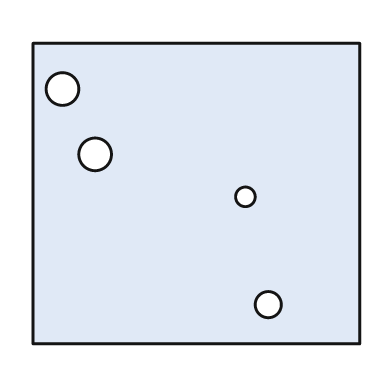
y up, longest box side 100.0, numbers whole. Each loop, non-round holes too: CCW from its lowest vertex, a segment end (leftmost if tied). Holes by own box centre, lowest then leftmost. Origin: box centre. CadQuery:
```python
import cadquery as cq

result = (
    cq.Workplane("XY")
    .moveTo(-50.0, -46.0)
    .lineTo(50.0, -46.0)
    .lineTo(50.0, 46.0)
    .lineTo(-50.0, 46.0)
    .close()
    .moveTo(22.0, -34.0)
    .circle(4.0)
    .moveTo(15.0, -1.0)
    .circle(3.0)
    .moveTo(-31.0, 12.0)
    .circle(5.0)
    .moveTo(-41.0, 32.0)
    .circle(5.0)
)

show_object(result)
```